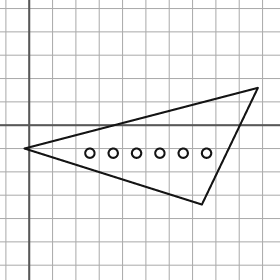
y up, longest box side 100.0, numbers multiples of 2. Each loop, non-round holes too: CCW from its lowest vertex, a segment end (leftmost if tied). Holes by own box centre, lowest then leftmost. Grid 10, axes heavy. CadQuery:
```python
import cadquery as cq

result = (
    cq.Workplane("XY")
    .moveTo(74.0, -34.0)
    .lineTo(98.0, 16.0)
    .lineTo(-2.0, -10.0)
    .close()
    .moveTo(26.0, -12.0)
    .circle(2.0)
    .moveTo(36.0, -12.0)
    .circle(2.0)
    .moveTo(46.0, -12.0)
    .circle(2.0)
    .moveTo(56.0, -12.0)
    .circle(2.0)
    .moveTo(66.0, -12.0)
    .circle(2.0)
    .moveTo(76.0, -12.0)
    .circle(2.0)
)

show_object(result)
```